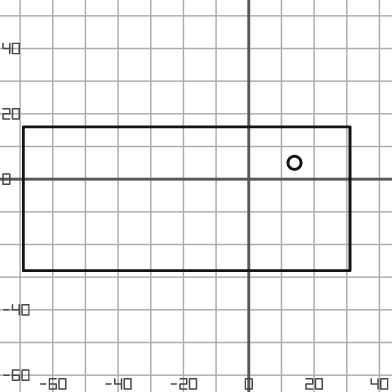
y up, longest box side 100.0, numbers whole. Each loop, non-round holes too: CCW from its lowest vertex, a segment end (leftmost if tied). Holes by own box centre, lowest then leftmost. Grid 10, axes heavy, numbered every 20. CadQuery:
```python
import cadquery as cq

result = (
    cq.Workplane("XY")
    .moveTo(-69.0, -28.0)
    .lineTo(31.0, -28.0)
    .lineTo(31.0, 16.0)
    .lineTo(-69.0, 16.0)
    .close()
    .moveTo(14.0, 5.0)
    .circle(2.0)
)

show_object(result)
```